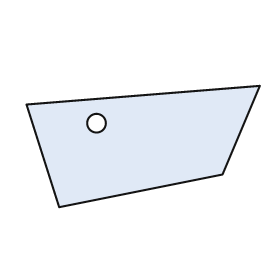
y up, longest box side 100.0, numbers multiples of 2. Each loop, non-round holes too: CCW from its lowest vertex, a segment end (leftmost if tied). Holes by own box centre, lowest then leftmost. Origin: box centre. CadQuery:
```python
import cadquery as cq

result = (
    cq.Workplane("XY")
    .moveTo(-36.0, -26.0)
    .lineTo(34.0, -12.0)
    .lineTo(50.0, 26.0)
    .lineTo(-50.0, 18.0)
    .close()
    .moveTo(-20.0, 10.0)
    .circle(4.0)
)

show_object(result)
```